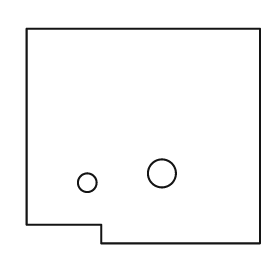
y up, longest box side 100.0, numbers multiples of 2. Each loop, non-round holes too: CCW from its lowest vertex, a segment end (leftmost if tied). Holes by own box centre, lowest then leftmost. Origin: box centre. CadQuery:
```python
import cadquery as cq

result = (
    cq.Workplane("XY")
    .moveTo(-18.0, -46.0)
    .lineTo(50.0, -46.0)
    .lineTo(50.0, 46.0)
    .lineTo(-50.0, 46.0)
    .lineTo(-50.0, -38.0)
    .lineTo(-18.0, -38.0)
    .close()
    .moveTo(-24.0, -20.0)
    .circle(4.0)
    .moveTo(8.0, -16.0)
    .circle(6.0)
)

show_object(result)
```